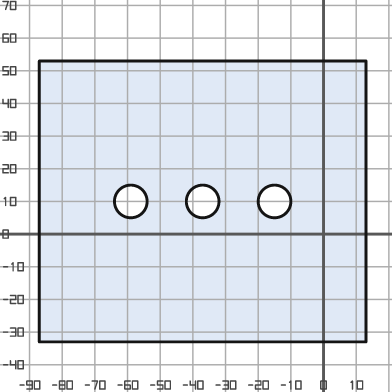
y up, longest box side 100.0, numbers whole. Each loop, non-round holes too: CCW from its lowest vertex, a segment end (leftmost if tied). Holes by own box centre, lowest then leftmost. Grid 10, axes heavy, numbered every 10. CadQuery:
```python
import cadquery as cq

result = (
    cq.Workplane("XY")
    .moveTo(-87.0, -33.0)
    .lineTo(13.0, -33.0)
    .lineTo(13.0, 53.0)
    .lineTo(-87.0, 53.0)
    .close()
    .moveTo(-59.0, 10.0)
    .circle(5.0)
    .moveTo(-37.0, 10.0)
    .circle(5.0)
    .moveTo(-15.0, 10.0)
    .circle(5.0)
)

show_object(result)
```